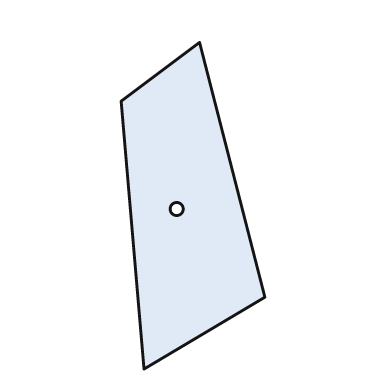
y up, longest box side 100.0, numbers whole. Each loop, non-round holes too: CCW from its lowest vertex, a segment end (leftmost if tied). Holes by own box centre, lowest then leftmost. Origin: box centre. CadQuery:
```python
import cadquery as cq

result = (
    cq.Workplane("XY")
    .moveTo(-15.0, -50.0)
    .lineTo(22.0, -28.0)
    .lineTo(2.0, 50.0)
    .lineTo(-22.0, 32.0)
    .close()
    .moveTo(-5.0, -1.0)
    .circle(2.0)
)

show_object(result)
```